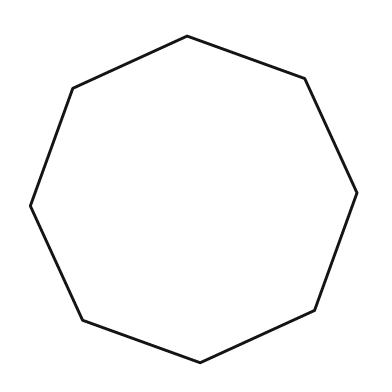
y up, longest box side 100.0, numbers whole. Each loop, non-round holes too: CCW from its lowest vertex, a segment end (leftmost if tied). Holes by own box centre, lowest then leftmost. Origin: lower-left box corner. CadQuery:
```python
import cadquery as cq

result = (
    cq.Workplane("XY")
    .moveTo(52.0, 0.0)
    .lineTo(87.0, 16.0)
    .lineTo(100.0, 52.0)
    .lineTo(84.0, 87.0)
    .lineTo(48.0, 100.0)
    .lineTo(13.0, 84.0)
    .lineTo(0.0, 48.0)
    .lineTo(16.0, 13.0)
    .close()
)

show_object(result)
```